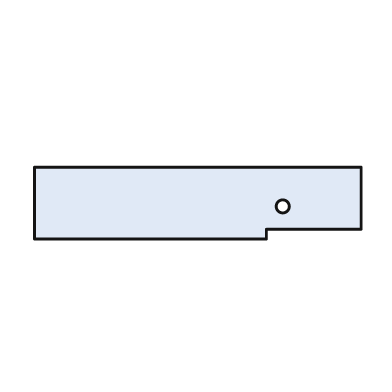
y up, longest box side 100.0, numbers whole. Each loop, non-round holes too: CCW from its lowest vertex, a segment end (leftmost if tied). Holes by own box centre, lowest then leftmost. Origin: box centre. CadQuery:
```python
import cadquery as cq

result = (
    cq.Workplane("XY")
    .moveTo(-50.0, -11.0)
    .lineTo(21.0, -11.0)
    .lineTo(21.0, -8.0)
    .lineTo(50.0, -8.0)
    .lineTo(50.0, 11.0)
    .lineTo(-50.0, 11.0)
    .close()
    .moveTo(26.0, -1.0)
    .circle(2.0)
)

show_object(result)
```